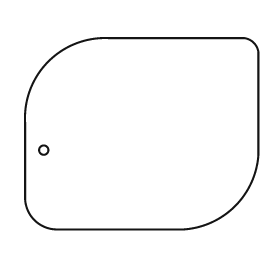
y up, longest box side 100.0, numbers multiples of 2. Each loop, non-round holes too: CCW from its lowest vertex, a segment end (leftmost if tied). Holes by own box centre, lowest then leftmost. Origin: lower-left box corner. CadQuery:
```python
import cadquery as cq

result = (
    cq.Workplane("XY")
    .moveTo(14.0, 0.0)
    .lineTo(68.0, 0.0)
    .threePointArc((90.0, 10.0), (100.0, 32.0))
    .lineTo(100.0, 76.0)
    .threePointArc((98.0, 80.0), (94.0, 82.0))
    .lineTo(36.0, 82.0)
    .threePointArc((10.0, 72.0), (0.0, 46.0))
    .lineTo(0.0, 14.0)
    .threePointArc((4.0, 4.0), (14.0, 0.0))
    .close()
    .moveTo(8.0, 34.0)
    .circle(2.0)
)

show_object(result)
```